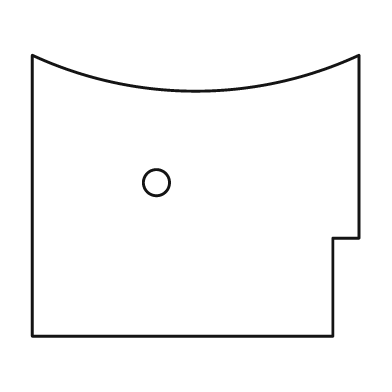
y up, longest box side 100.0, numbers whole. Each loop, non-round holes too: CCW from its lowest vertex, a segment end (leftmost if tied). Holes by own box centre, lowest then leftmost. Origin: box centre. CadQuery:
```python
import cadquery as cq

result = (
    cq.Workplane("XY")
    .moveTo(-50.0, -43.0)
    .lineTo(42.0, -43.0)
    .lineTo(42.0, -13.0)
    .lineTo(50.0, -13.0)
    .lineTo(50.0, 43.0)
    .threePointArc((0.0, 32.0), (-50.0, 43.0))
    .close()
    .moveTo(-12.0, 4.0)
    .circle(4.0)
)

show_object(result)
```